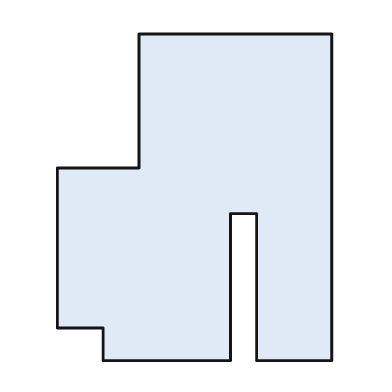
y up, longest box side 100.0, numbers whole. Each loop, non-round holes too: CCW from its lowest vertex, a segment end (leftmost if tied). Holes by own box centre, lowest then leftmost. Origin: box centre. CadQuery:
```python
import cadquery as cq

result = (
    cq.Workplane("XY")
    .moveTo(-28.0, -50.0)
    .lineTo(11.0, -50.0)
    .lineTo(11.0, -5.0)
    .lineTo(19.0, -5.0)
    .lineTo(19.0, -50.0)
    .lineTo(42.0, -50.0)
    .lineTo(42.0, 50.0)
    .lineTo(-17.0, 50.0)
    .lineTo(-17.0, 9.0)
    .lineTo(-42.0, 9.0)
    .lineTo(-42.0, -40.0)
    .lineTo(-28.0, -40.0)
    .close()
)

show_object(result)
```